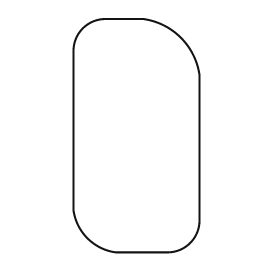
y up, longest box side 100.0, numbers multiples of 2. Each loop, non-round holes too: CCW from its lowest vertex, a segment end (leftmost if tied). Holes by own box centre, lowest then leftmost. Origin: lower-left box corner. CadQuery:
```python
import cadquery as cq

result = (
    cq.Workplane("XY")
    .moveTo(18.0, 0.0)
    .lineTo(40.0, 0.0)
    .threePointArc((50.0, 4.0), (54.0, 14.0))
    .lineTo(54.0, 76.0)
    .threePointArc((46.0, 92.0), (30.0, 100.0))
    .lineTo(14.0, 100.0)
    .threePointArc((4.0, 96.0), (0.0, 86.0))
    .lineTo(0.0, 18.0)
    .threePointArc((6.0, 6.0), (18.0, 0.0))
    .close()
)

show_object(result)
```